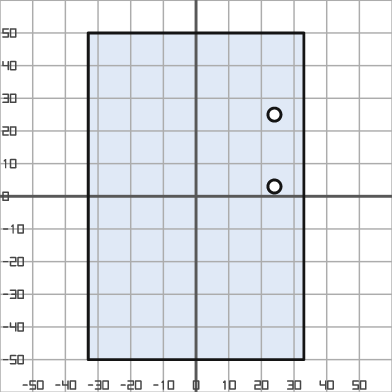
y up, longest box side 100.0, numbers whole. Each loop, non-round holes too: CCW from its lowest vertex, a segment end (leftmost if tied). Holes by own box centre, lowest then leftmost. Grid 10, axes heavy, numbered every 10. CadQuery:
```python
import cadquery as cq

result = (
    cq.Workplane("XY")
    .moveTo(-33.0, -50.0)
    .lineTo(33.0, -50.0)
    .lineTo(33.0, 50.0)
    .lineTo(-33.0, 50.0)
    .close()
    .moveTo(24.0, 3.0)
    .circle(2.0)
    .moveTo(24.0, 25.0)
    .circle(2.0)
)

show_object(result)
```